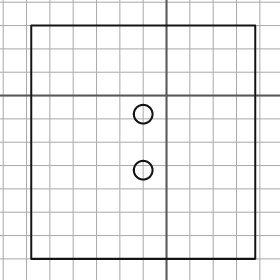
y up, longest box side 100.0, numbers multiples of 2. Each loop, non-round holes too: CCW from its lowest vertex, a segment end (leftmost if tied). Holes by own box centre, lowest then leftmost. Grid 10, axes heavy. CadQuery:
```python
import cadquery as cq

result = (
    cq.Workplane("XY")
    .moveTo(-58.0, -70.0)
    .lineTo(38.0, -70.0)
    .lineTo(38.0, 30.0)
    .lineTo(-58.0, 30.0)
    .close()
    .moveTo(-10.0, -32.0)
    .circle(4.0)
    .moveTo(-10.0, -8.0)
    .circle(4.0)
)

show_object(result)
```